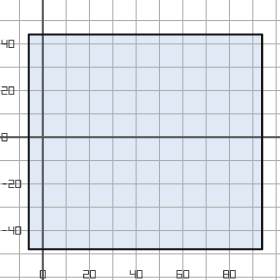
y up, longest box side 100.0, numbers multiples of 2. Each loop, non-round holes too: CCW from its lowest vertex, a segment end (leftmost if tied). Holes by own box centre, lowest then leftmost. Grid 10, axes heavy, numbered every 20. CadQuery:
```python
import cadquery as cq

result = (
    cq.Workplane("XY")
    .moveTo(-6.0, -48.0)
    .lineTo(94.0, -48.0)
    .lineTo(94.0, 44.0)
    .lineTo(-6.0, 44.0)
    .close()
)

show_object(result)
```